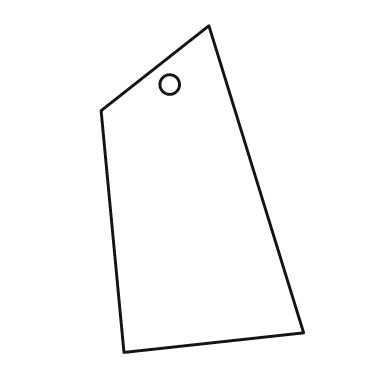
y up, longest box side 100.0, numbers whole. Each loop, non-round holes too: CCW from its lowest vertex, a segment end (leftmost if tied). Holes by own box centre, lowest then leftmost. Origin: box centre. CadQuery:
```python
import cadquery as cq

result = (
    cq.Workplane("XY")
    .moveTo(-24.0, -50.0)
    .lineTo(31.0, -44.0)
    .lineTo(2.0, 50.0)
    .lineTo(-31.0, 24.0)
    .close()
    .moveTo(-10.0, 32.0)
    .circle(3.0)
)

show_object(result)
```